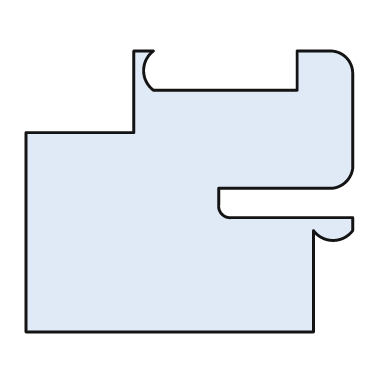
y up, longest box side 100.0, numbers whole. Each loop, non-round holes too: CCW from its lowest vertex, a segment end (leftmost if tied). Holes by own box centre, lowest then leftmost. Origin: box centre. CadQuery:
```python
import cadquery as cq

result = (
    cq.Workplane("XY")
    .moveTo(-50.0, -43.0)
    .lineTo(38.0, -43.0)
    .lineTo(38.0, -12.0)
    .threePointArc((44.0, -15.0), (50.0, -12.0))
    .lineTo(50.0, -8.0)
    .lineTo(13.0, -8.0)
    .threePointArc((10.0, -7.0), (9.0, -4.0))
    .lineTo(9.0, 1.0)
    .lineTo(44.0, 1.0)
    .threePointArc((48.0, 3.0), (50.0, 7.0))
    .lineTo(50.0, 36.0)
    .threePointArc((48.0, 41.0), (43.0, 43.0))
    .lineTo(33.0, 43.0)
    .lineTo(33.0, 31.0)
    .lineTo(-11.0, 31.0)
    .threePointArc((-14.0, 37.0), (-11.0, 43.0))
    .lineTo(-17.0, 43.0)
    .lineTo(-17.0, 18.0)
    .lineTo(-50.0, 18.0)
    .close()
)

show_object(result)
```